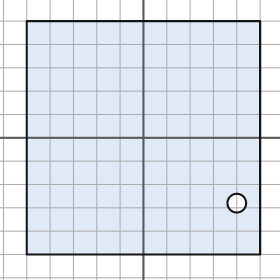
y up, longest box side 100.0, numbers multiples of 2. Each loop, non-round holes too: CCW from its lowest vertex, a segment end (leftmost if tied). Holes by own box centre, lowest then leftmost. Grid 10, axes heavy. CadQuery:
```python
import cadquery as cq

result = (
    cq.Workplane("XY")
    .moveTo(-50.0, -50.0)
    .lineTo(50.0, -50.0)
    .lineTo(50.0, 50.0)
    .lineTo(-50.0, 50.0)
    .close()
    .moveTo(40.0, -28.0)
    .circle(4.0)
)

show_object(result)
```